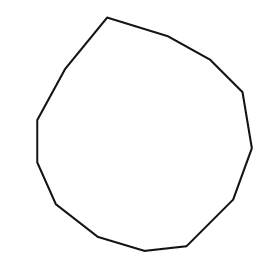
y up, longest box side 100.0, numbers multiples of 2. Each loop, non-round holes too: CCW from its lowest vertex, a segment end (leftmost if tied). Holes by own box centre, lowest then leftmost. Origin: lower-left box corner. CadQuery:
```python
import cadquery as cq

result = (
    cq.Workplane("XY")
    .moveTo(46.0, 0.0)
    .lineTo(64.0, 2.0)
    .lineTo(84.0, 22.0)
    .lineTo(92.0, 44.0)
    .lineTo(88.0, 68.0)
    .lineTo(74.0, 82.0)
    .lineTo(56.0, 92.0)
    .lineTo(30.0, 100.0)
    .lineTo(12.0, 78.0)
    .lineTo(0.0, 56.0)
    .lineTo(0.0, 38.0)
    .lineTo(8.0, 20.0)
    .lineTo(26.0, 6.0)
    .close()
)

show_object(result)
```